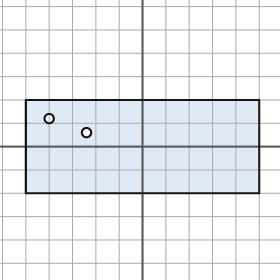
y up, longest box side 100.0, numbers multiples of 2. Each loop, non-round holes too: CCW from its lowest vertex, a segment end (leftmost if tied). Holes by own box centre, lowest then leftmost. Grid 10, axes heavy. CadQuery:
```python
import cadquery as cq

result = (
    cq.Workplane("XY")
    .moveTo(-50.0, -20.0)
    .lineTo(50.0, -20.0)
    .lineTo(50.0, 20.0)
    .lineTo(-50.0, 20.0)
    .close()
    .moveTo(-24.0, 6.0)
    .circle(2.0)
    .moveTo(-40.0, 12.0)
    .circle(2.0)
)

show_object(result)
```